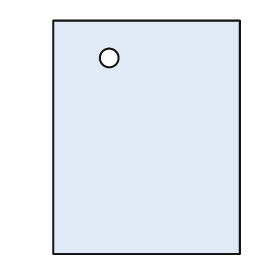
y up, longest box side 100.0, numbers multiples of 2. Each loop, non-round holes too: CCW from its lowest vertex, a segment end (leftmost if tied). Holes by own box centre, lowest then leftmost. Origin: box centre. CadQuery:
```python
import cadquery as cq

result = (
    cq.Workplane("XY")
    .moveTo(-40.0, -50.0)
    .lineTo(40.0, -50.0)
    .lineTo(40.0, 50.0)
    .lineTo(-40.0, 50.0)
    .close()
    .moveTo(-16.0, 34.0)
    .circle(4.0)
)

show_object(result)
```